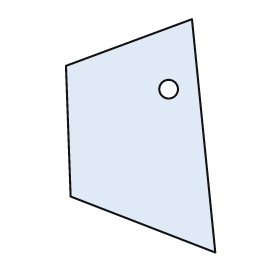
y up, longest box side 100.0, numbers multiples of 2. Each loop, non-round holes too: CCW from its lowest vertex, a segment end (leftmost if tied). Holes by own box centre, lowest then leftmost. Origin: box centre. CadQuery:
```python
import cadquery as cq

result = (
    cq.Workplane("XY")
    .moveTo(32.0, -50.0)
    .lineTo(22.0, 50.0)
    .lineTo(-32.0, 30.0)
    .lineTo(-30.0, -26.0)
    .close()
    .moveTo(12.0, 20.0)
    .circle(4.0)
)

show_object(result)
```